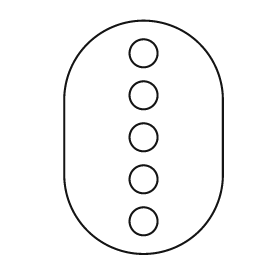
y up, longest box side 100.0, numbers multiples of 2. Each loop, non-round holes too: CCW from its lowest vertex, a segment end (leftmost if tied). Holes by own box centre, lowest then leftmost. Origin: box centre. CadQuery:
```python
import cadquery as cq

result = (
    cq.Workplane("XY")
    .moveTo(-34.0, -16.0)
    .threePointArc((0.0, -50.0), (34.0, -16.0))
    .lineTo(34.0, 16.0)
    .threePointArc((0.0, 50.0), (-34.0, 16.0))
    .close()
    .moveTo(0.0, -36.0)
    .circle(6.0)
    .moveTo(0.0, -18.0)
    .circle(6.0)
    .moveTo(0.0, 0.0)
    .circle(6.0)
    .moveTo(0.0, 18.0)
    .circle(6.0)
    .moveTo(0.0, 36.0)
    .circle(6.0)
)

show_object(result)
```